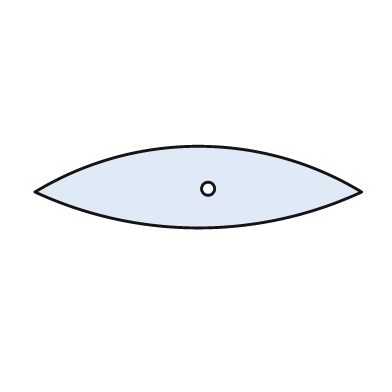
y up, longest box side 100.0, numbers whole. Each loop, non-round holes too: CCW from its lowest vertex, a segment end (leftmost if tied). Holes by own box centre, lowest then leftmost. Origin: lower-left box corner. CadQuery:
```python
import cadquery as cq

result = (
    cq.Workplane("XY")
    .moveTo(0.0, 11.0)
    .threePointArc((50.0, 0.0), (100.0, 11.0))
    .threePointArc((50.0, 25.0), (0.0, 11.0))
    .close()
    .moveTo(53.0, 12.0)
    .circle(2.0)
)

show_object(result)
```